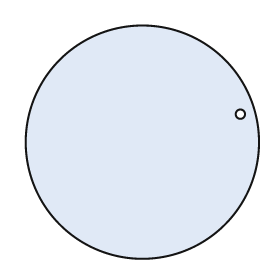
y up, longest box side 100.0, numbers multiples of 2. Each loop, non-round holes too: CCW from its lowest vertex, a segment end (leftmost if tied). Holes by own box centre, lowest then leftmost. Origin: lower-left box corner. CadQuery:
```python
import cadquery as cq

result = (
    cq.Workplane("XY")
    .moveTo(50.0, 50.0)
    .circle(50.0)
    .moveTo(92.0, 62.0)
    .circle(2.0)
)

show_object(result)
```